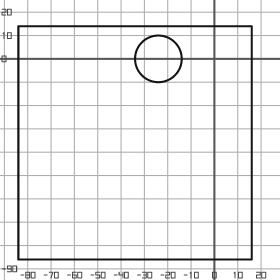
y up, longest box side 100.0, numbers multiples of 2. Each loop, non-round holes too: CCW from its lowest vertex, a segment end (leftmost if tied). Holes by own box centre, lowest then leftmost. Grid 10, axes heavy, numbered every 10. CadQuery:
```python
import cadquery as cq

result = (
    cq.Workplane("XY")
    .moveTo(-84.0, -86.0)
    .lineTo(16.0, -86.0)
    .lineTo(16.0, 14.0)
    .lineTo(-84.0, 14.0)
    .close()
    .moveTo(-24.0, 0.0)
    .circle(10.0)
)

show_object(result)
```